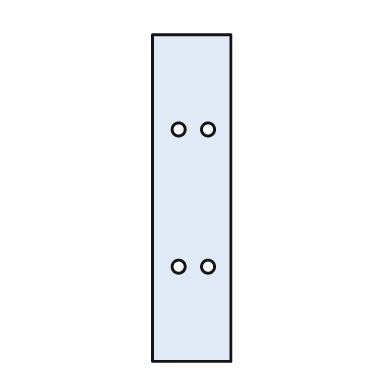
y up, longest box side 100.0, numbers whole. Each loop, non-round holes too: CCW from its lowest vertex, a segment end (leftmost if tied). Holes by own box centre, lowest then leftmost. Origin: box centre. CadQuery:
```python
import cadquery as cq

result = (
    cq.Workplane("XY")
    .moveTo(-12.0, -50.0)
    .lineTo(12.0, -50.0)
    .lineTo(12.0, 50.0)
    .lineTo(-12.0, 50.0)
    .close()
    .moveTo(-4.0, -21.0)
    .circle(2.0)
    .moveTo(5.0, -21.0)
    .circle(2.0)
    .moveTo(-4.0, 21.0)
    .circle(2.0)
    .moveTo(5.0, 21.0)
    .circle(2.0)
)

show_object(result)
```